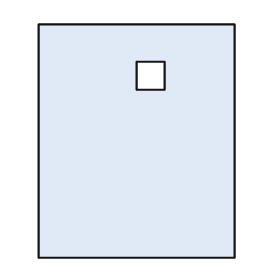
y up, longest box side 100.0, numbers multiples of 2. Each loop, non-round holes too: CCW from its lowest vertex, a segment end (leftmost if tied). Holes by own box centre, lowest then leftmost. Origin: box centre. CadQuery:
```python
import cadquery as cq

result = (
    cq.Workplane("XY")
    .moveTo(-42.0, -50.0)
    .lineTo(42.0, -50.0)
    .lineTo(42.0, 50.0)
    .lineTo(-42.0, 50.0)
    .close()
    .moveTo(0.0, 22.0)
    .lineTo(12.0, 22.0)
    .lineTo(12.0, 34.0)
    .lineTo(0.0, 34.0)
    .close()
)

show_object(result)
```